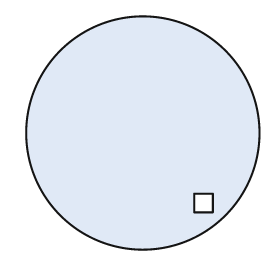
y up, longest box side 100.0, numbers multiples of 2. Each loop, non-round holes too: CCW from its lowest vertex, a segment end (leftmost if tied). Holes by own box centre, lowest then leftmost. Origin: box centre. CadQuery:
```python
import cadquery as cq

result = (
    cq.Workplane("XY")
    .moveTo(0.0, 0.0)
    .circle(50.0)
    .moveTo(22.0, -34.0)
    .lineTo(30.0, -34.0)
    .lineTo(30.0, -26.0)
    .lineTo(22.0, -26.0)
    .close()
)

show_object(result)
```